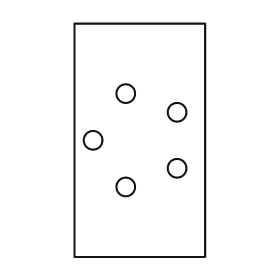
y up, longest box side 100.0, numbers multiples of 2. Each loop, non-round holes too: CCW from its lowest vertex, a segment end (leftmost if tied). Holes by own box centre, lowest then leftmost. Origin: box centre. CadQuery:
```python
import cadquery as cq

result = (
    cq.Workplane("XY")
    .moveTo(-28.0, -50.0)
    .lineTo(28.0, -50.0)
    .lineTo(28.0, 50.0)
    .lineTo(-28.0, 50.0)
    .close()
    .moveTo(-6.0, -20.0)
    .circle(4.0)
    .moveTo(16.0, -12.0)
    .circle(4.0)
    .moveTo(-20.0, 0.0)
    .circle(4.0)
    .moveTo(16.0, 12.0)
    .circle(4.0)
    .moveTo(-6.0, 20.0)
    .circle(4.0)
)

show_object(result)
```